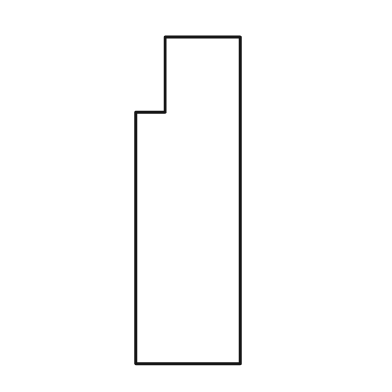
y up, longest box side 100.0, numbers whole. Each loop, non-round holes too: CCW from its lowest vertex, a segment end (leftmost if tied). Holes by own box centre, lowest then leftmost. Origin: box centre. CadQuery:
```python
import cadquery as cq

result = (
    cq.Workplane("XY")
    .moveTo(-16.0, -50.0)
    .lineTo(16.0, -50.0)
    .lineTo(16.0, 50.0)
    .lineTo(-7.0, 50.0)
    .lineTo(-7.0, 27.0)
    .lineTo(-16.0, 27.0)
    .close()
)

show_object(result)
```